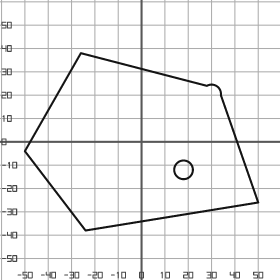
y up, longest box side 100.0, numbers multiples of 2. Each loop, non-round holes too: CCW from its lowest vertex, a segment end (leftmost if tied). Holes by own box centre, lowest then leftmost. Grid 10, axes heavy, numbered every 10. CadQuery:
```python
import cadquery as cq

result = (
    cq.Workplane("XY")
    .moveTo(-24.0, -38.0)
    .lineTo(50.0, -26.0)
    .lineTo(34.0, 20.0)
    .threePointArc((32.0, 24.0), (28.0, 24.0))
    .lineTo(-26.0, 38.0)
    .lineTo(-50.0, -4.0)
    .close()
    .moveTo(18.0, -12.0)
    .circle(4.0)
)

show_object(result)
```